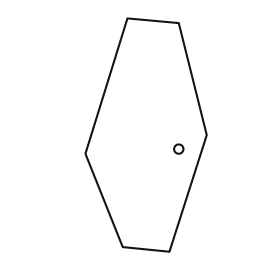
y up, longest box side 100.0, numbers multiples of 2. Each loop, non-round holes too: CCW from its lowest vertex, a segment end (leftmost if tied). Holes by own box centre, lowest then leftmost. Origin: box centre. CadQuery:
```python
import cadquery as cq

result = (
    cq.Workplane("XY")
    .moveTo(10.0, -50.0)
    .lineTo(26.0, 0.0)
    .lineTo(14.0, 48.0)
    .lineTo(-8.0, 50.0)
    .lineTo(-26.0, -8.0)
    .lineTo(-10.0, -48.0)
    .close()
    .moveTo(14.0, -6.0)
    .circle(2.0)
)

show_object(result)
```